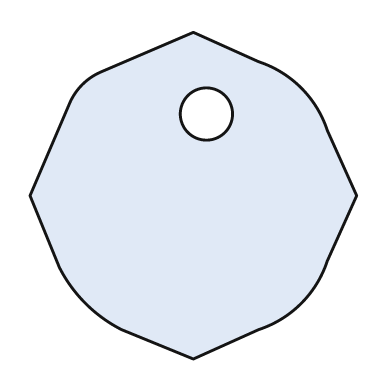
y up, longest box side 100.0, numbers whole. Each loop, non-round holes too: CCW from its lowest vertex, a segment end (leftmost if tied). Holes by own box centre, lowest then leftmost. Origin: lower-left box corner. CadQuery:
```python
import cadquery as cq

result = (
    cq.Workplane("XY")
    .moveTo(50.0, 0.0)
    .lineTo(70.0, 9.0)
    .threePointArc((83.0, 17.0), (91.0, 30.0))
    .lineTo(100.0, 50.0)
    .lineTo(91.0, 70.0)
    .threePointArc((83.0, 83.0), (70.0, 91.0))
    .lineTo(50.0, 100.0)
    .lineTo(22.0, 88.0)
    .threePointArc((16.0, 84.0), (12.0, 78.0))
    .lineTo(0.0, 50.0)
    .lineTo(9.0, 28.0)
    .threePointArc((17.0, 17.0), (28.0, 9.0))
    .close()
    .moveTo(54.0, 75.0)
    .circle(8.0)
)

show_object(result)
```